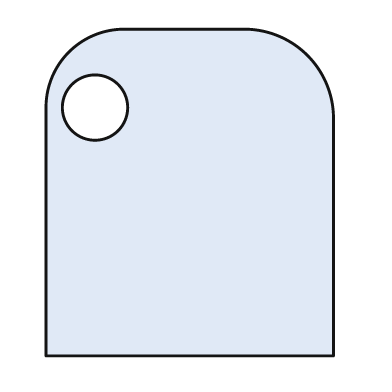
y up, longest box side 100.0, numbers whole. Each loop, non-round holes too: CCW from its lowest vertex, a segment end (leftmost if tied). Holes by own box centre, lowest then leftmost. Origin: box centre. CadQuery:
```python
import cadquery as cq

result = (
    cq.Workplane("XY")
    .moveTo(-44.0, -50.0)
    .lineTo(44.0, -50.0)
    .lineTo(44.0, 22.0)
    .threePointArc((36.0, 42.0), (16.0, 50.0))
    .lineTo(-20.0, 50.0)
    .threePointArc((-37.0, 43.0), (-44.0, 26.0))
    .close()
    .moveTo(-29.0, 26.0)
    .circle(10.0)
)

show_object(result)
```